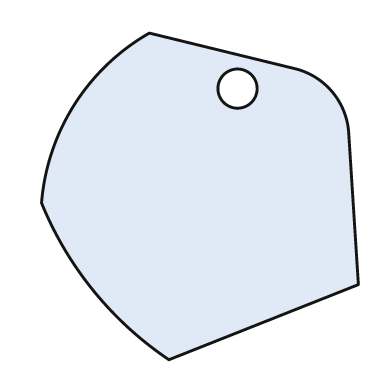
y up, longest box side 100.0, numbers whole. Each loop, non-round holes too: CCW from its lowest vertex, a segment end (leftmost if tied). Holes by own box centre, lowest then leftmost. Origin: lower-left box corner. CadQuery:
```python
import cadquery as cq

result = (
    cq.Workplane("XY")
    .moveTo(39.0, 0.0)
    .lineTo(97.0, 23.0)
    .lineTo(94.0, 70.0)
    .threePointArc((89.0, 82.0), (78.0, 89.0))
    .lineTo(33.0, 100.0)
    .threePointArc((10.0, 78.0), (0.0, 48.0))
    .threePointArc((16.0, 21.0), (39.0, 0.0))
    .close()
    .moveTo(60.0, 83.0)
    .circle(6.0)
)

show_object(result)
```